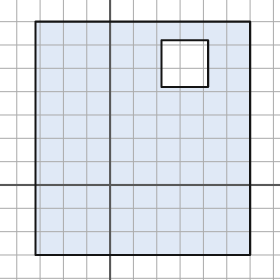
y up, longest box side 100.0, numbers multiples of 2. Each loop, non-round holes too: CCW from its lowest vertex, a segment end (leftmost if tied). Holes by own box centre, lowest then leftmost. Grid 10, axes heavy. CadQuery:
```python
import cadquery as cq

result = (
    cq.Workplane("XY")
    .moveTo(-32.0, -30.0)
    .lineTo(60.0, -30.0)
    .lineTo(60.0, 70.0)
    .lineTo(-32.0, 70.0)
    .close()
    .moveTo(22.0, 42.0)
    .lineTo(42.0, 42.0)
    .lineTo(42.0, 62.0)
    .lineTo(22.0, 62.0)
    .close()
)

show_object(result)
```